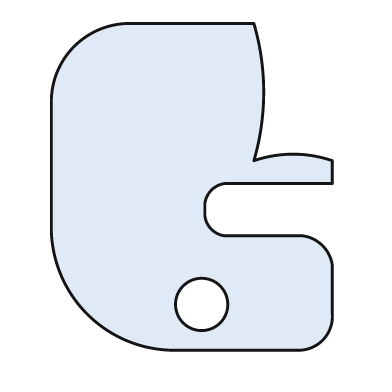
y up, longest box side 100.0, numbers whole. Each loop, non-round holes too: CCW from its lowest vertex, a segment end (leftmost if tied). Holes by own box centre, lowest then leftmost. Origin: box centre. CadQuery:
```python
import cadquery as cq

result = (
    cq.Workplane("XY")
    .moveTo(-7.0, -50.0)
    .lineTo(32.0, -50.0)
    .threePointArc((40.0, -47.0), (43.0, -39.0))
    .lineTo(43.0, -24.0)
    .threePointArc((40.0, -18.0), (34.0, -15.0))
    .lineTo(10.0, -15.0)
    .threePointArc((6.0, -13.0), (4.0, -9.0))
    .lineTo(4.0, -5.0)
    .threePointArc((6.0, -1.0), (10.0, 1.0))
    .lineTo(43.0, 1.0)
    .lineTo(43.0, 8.0)
    .threePointArc((31.0, 10.0), (19.0, 8.0))
    .threePointArc((22.0, 29.0), (19.0, 50.0))
    .lineTo(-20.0, 50.0)
    .threePointArc((-36.0, 43.0), (-43.0, 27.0))
    .lineTo(-43.0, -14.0)
    .threePointArc((-32.0, -39.0), (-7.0, -50.0))
    .close()
    .moveTo(3.0, -36.0)
    .circle(8.0)
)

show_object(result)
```